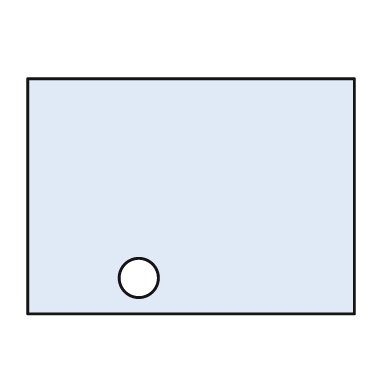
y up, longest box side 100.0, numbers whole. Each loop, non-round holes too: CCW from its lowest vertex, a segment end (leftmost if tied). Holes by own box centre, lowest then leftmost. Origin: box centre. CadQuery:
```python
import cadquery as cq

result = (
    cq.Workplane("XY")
    .moveTo(-50.0, -36.0)
    .lineTo(50.0, -36.0)
    .lineTo(50.0, 36.0)
    .lineTo(-50.0, 36.0)
    .close()
    .moveTo(-16.0, -25.0)
    .circle(6.0)
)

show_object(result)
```